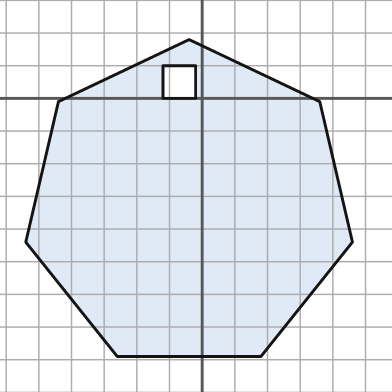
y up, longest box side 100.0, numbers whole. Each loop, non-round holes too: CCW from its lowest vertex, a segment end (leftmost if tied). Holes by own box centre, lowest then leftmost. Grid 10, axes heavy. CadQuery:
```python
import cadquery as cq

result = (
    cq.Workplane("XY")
    .moveTo(-26.0, -79.0)
    .lineTo(18.0, -79.0)
    .lineTo(46.0, -44.0)
    .lineTo(36.0, -1.0)
    .lineTo(-4.0, 18.0)
    .lineTo(-44.0, -1.0)
    .lineTo(-54.0, -44.0)
    .close()
    .moveTo(-12.0, 0.0)
    .lineTo(-2.0, 0.0)
    .lineTo(-2.0, 10.0)
    .lineTo(-12.0, 10.0)
    .close()
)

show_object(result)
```